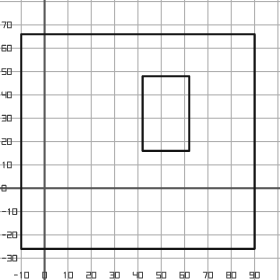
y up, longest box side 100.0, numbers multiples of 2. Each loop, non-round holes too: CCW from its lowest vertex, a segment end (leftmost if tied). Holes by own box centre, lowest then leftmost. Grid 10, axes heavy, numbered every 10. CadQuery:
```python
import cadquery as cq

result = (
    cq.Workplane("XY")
    .moveTo(-10.0, -26.0)
    .lineTo(90.0, -26.0)
    .lineTo(90.0, 66.0)
    .lineTo(-10.0, 66.0)
    .close()
    .moveTo(42.0, 16.0)
    .lineTo(62.0, 16.0)
    .lineTo(62.0, 48.0)
    .lineTo(42.0, 48.0)
    .close()
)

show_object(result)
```